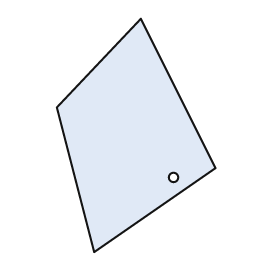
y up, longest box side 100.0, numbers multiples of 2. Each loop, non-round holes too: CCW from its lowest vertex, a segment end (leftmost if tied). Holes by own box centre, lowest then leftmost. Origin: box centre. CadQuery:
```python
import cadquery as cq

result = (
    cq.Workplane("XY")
    .moveTo(-18.0, -50.0)
    .lineTo(34.0, -14.0)
    .lineTo(2.0, 50.0)
    .lineTo(-34.0, 12.0)
    .close()
    .moveTo(16.0, -18.0)
    .circle(2.0)
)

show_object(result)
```